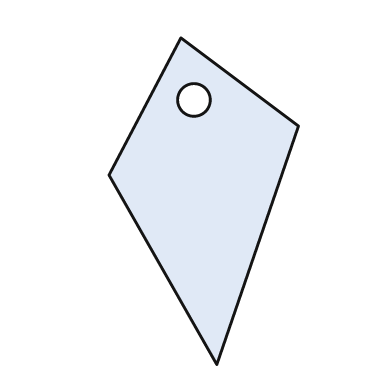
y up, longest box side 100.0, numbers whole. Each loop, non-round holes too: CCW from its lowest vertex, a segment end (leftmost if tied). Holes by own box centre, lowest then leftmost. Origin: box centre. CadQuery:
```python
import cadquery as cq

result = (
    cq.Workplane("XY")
    .moveTo(4.0, -50.0)
    .lineTo(29.0, 23.0)
    .lineTo(-7.0, 50.0)
    .lineTo(-29.0, 8.0)
    .close()
    .moveTo(-3.0, 31.0)
    .circle(5.0)
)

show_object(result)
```